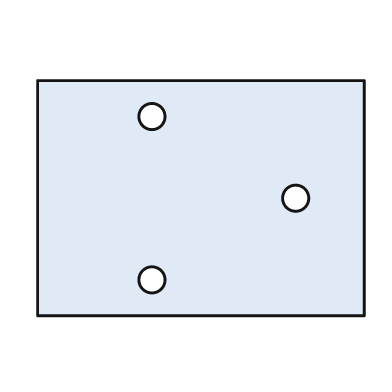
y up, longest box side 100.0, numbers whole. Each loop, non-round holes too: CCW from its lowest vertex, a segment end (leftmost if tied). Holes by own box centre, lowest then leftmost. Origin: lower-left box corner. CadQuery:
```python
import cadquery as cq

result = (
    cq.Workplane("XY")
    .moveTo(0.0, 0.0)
    .lineTo(100.0, 0.0)
    .lineTo(100.0, 72.0)
    .lineTo(0.0, 72.0)
    .close()
    .moveTo(35.0, 11.0)
    .circle(4.0)
    .moveTo(79.0, 36.0)
    .circle(4.0)
    .moveTo(35.0, 61.0)
    .circle(4.0)
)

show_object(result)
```